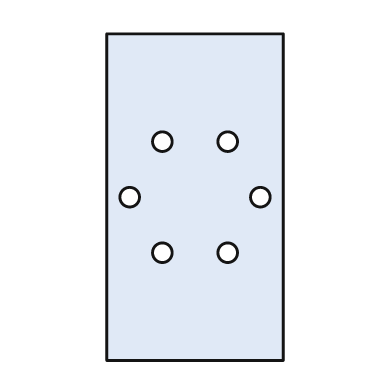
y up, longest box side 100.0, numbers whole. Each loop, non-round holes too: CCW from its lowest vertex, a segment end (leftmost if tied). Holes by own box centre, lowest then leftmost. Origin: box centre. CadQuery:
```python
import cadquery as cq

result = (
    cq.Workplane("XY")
    .moveTo(-27.0, -50.0)
    .lineTo(27.0, -50.0)
    .lineTo(27.0, 50.0)
    .lineTo(-27.0, 50.0)
    .close()
    .moveTo(-10.0, -17.0)
    .circle(3.0)
    .moveTo(10.0, -17.0)
    .circle(3.0)
    .moveTo(-20.0, 0.0)
    .circle(3.0)
    .moveTo(20.0, 0.0)
    .circle(3.0)
    .moveTo(-10.0, 17.0)
    .circle(3.0)
    .moveTo(10.0, 17.0)
    .circle(3.0)
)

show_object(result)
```